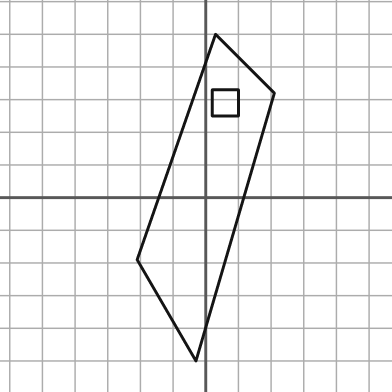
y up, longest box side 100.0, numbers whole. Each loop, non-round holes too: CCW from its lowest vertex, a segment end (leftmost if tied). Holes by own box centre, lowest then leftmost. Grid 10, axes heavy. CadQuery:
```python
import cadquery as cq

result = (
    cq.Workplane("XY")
    .moveTo(-3.0, -50.0)
    .lineTo(21.0, 32.0)
    .lineTo(3.0, 50.0)
    .lineTo(-21.0, -19.0)
    .close()
    .moveTo(2.0, 25.0)
    .lineTo(10.0, 25.0)
    .lineTo(10.0, 33.0)
    .lineTo(2.0, 33.0)
    .close()
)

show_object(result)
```